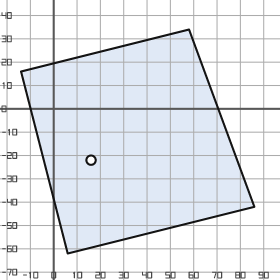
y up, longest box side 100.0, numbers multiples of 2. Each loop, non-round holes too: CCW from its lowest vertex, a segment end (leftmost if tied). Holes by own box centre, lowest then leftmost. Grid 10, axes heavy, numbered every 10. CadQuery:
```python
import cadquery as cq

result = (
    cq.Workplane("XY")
    .moveTo(6.0, -62.0)
    .lineTo(86.0, -42.0)
    .lineTo(58.0, 34.0)
    .lineTo(-14.0, 16.0)
    .close()
    .moveTo(16.0, -22.0)
    .circle(2.0)
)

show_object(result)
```